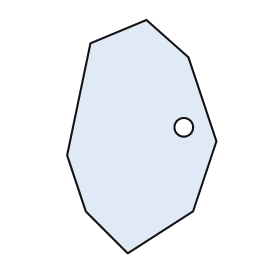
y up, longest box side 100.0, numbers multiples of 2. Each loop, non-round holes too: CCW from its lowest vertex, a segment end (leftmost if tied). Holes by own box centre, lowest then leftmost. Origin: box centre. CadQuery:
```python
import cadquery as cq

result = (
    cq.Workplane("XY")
    .moveTo(-6.0, -50.0)
    .lineTo(22.0, -32.0)
    .lineTo(32.0, -2.0)
    .lineTo(20.0, 34.0)
    .lineTo(2.0, 50.0)
    .lineTo(-22.0, 40.0)
    .lineTo(-32.0, -8.0)
    .lineTo(-24.0, -32.0)
    .close()
    .moveTo(18.0, 4.0)
    .circle(4.0)
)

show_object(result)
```